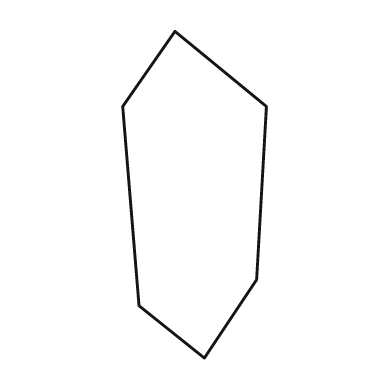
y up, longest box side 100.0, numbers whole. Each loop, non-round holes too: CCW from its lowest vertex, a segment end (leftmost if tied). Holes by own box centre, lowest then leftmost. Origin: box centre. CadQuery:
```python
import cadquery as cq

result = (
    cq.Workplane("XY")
    .moveTo(3.0, -50.0)
    .lineTo(19.0, -26.0)
    .lineTo(22.0, 27.0)
    .lineTo(-6.0, 50.0)
    .lineTo(-22.0, 27.0)
    .lineTo(-17.0, -34.0)
    .close()
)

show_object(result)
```